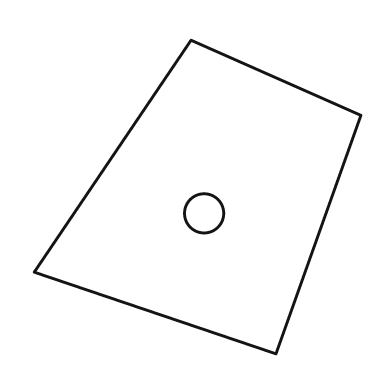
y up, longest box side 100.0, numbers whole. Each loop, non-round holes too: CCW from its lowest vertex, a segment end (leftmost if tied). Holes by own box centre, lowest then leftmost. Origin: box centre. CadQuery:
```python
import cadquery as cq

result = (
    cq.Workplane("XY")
    .moveTo(24.0, -48.0)
    .lineTo(50.0, 25.0)
    .lineTo(-2.0, 48.0)
    .lineTo(-50.0, -23.0)
    .close()
    .moveTo(2.0, -5.0)
    .circle(6.0)
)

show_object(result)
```